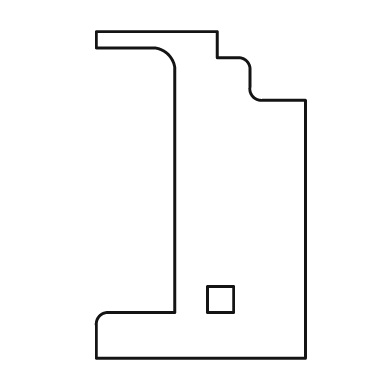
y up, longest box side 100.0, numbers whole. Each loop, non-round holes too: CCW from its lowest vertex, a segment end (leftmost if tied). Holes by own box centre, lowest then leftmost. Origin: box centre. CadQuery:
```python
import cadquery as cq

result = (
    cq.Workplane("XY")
    .moveTo(-32.0, -50.0)
    .lineTo(32.0, -50.0)
    .lineTo(32.0, 29.0)
    .lineTo(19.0, 29.0)
    .threePointArc((16.0, 30.0), (15.0, 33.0))
    .lineTo(15.0, 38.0)
    .threePointArc((14.0, 41.0), (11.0, 42.0))
    .lineTo(5.0, 42.0)
    .lineTo(5.0, 50.0)
    .lineTo(-32.0, 50.0)
    .lineTo(-32.0, 45.0)
    .lineTo(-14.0, 45.0)
    .threePointArc((-10.0, 43.0), (-8.0, 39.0))
    .lineTo(-8.0, -36.0)
    .lineTo(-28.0, -36.0)
    .threePointArc((-31.0, -37.0), (-32.0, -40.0))
    .close()
    .moveTo(2.0, -36.0)
    .lineTo(10.0, -36.0)
    .lineTo(10.0, -28.0)
    .lineTo(2.0, -28.0)
    .close()
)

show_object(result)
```